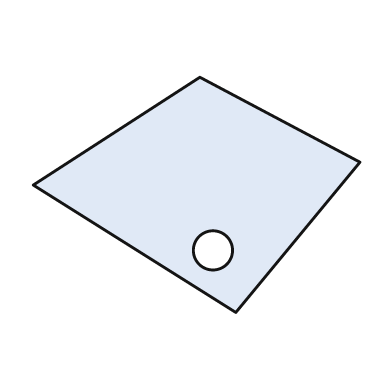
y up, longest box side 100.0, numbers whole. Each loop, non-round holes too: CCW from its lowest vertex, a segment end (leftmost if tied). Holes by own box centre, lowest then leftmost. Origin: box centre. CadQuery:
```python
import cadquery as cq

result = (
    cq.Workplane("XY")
    .moveTo(12.0, -36.0)
    .lineTo(50.0, 10.0)
    .lineTo(1.0, 36.0)
    .lineTo(-50.0, 3.0)
    .close()
    .moveTo(5.0, -17.0)
    .circle(6.0)
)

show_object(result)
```